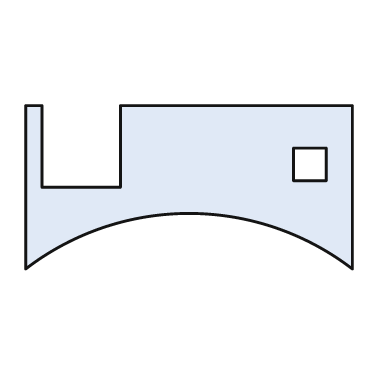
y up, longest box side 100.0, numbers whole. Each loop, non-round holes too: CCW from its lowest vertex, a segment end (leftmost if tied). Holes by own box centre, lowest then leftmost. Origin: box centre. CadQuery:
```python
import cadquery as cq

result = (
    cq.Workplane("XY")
    .moveTo(-50.0, -25.0)
    .threePointArc((0.0, -8.0), (50.0, -25.0))
    .lineTo(50.0, 25.0)
    .lineTo(-21.0, 25.0)
    .lineTo(-21.0, 0.0)
    .lineTo(-45.0, 0.0)
    .lineTo(-45.0, 25.0)
    .lineTo(-50.0, 25.0)
    .close()
    .moveTo(32.0, 2.0)
    .lineTo(42.0, 2.0)
    .lineTo(42.0, 12.0)
    .lineTo(32.0, 12.0)
    .close()
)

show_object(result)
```